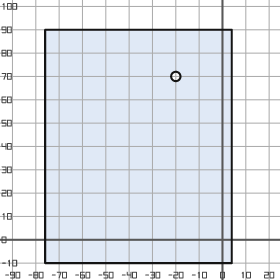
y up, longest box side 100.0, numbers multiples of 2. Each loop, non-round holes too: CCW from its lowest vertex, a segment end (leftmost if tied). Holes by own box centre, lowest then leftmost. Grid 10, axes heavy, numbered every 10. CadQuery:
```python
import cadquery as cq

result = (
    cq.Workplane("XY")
    .moveTo(-76.0, -10.0)
    .lineTo(4.0, -10.0)
    .lineTo(4.0, 90.0)
    .lineTo(-76.0, 90.0)
    .close()
    .moveTo(-20.0, 70.0)
    .circle(2.0)
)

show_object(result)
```